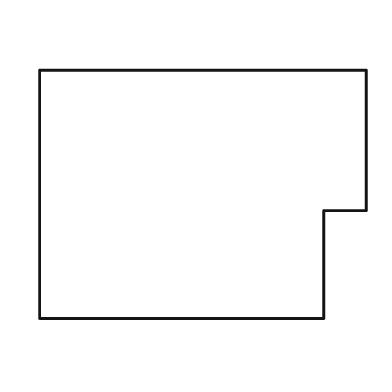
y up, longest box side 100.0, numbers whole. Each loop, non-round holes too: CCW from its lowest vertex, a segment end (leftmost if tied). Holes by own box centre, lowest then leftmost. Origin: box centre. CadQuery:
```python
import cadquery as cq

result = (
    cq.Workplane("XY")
    .moveTo(-50.0, -38.0)
    .lineTo(37.0, -38.0)
    .lineTo(37.0, -5.0)
    .lineTo(50.0, -5.0)
    .lineTo(50.0, 38.0)
    .lineTo(-50.0, 38.0)
    .close()
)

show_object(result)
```